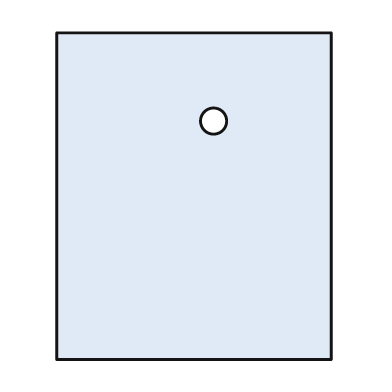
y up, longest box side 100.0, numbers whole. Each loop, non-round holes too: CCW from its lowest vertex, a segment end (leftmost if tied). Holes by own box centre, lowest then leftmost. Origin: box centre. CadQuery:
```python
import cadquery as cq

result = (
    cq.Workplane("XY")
    .moveTo(-42.0, -50.0)
    .lineTo(42.0, -50.0)
    .lineTo(42.0, 50.0)
    .lineTo(-42.0, 50.0)
    .close()
    .moveTo(6.0, 23.0)
    .circle(4.0)
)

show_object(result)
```